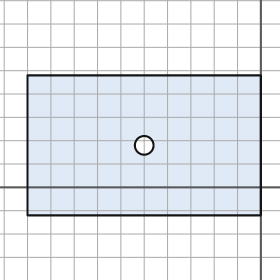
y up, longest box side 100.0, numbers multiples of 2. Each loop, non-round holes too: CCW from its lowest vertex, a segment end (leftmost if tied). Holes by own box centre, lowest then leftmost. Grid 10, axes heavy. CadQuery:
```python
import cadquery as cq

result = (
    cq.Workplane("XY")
    .moveTo(-100.0, -12.0)
    .lineTo(0.0, -12.0)
    .lineTo(0.0, 48.0)
    .lineTo(-100.0, 48.0)
    .close()
    .moveTo(-50.0, 18.0)
    .circle(4.0)
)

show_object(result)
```